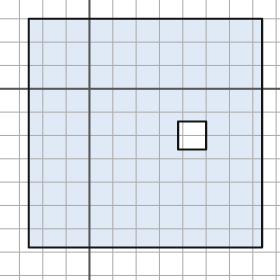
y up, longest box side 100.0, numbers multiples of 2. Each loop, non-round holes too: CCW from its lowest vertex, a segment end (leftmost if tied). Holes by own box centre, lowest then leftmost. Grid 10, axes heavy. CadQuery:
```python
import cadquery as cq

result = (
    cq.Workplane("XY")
    .moveTo(-26.0, -68.0)
    .lineTo(74.0, -68.0)
    .lineTo(74.0, 30.0)
    .lineTo(-26.0, 30.0)
    .close()
    .moveTo(38.0, -26.0)
    .lineTo(50.0, -26.0)
    .lineTo(50.0, -14.0)
    .lineTo(38.0, -14.0)
    .close()
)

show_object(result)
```